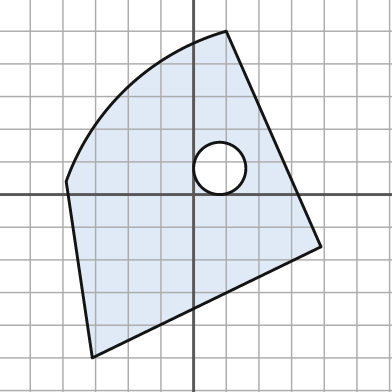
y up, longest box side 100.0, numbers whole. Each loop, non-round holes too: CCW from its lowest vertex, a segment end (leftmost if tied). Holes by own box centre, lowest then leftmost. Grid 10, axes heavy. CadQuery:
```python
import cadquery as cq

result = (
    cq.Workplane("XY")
    .moveTo(-31.0, -50.0)
    .lineTo(39.0, -16.0)
    .lineTo(10.0, 50.0)
    .threePointArc((-20.0, 33.0), (-39.0, 4.0))
    .close()
    .moveTo(8.0, 8.0)
    .circle(8.0)
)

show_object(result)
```